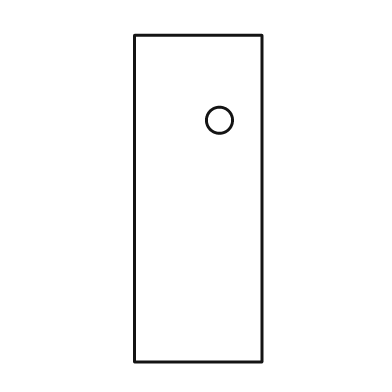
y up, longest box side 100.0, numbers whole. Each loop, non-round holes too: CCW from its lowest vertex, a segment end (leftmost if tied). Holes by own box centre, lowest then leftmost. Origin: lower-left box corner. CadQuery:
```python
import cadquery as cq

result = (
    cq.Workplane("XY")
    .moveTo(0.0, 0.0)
    .lineTo(39.0, 0.0)
    .lineTo(39.0, 100.0)
    .lineTo(0.0, 100.0)
    .close()
    .moveTo(26.0, 74.0)
    .circle(4.0)
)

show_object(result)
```